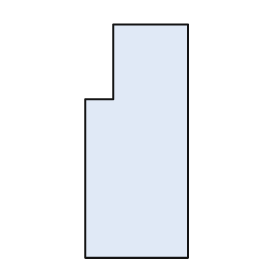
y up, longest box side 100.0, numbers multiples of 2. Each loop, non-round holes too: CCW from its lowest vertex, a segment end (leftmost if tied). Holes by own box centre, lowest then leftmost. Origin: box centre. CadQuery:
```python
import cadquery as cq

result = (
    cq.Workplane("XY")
    .moveTo(-22.0, -50.0)
    .lineTo(22.0, -50.0)
    .lineTo(22.0, 50.0)
    .lineTo(-10.0, 50.0)
    .lineTo(-10.0, 18.0)
    .lineTo(-22.0, 18.0)
    .close()
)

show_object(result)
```